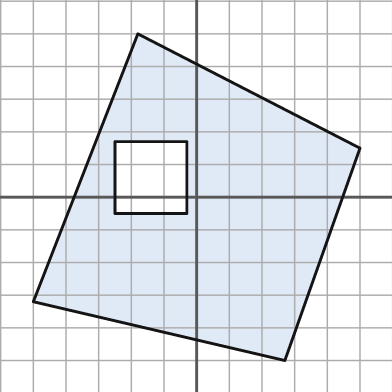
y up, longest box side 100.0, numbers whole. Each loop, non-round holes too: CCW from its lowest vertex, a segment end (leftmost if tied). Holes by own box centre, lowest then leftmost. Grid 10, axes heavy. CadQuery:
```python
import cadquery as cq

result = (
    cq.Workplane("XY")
    .moveTo(27.0, -50.0)
    .lineTo(50.0, 15.0)
    .lineTo(-18.0, 50.0)
    .lineTo(-50.0, -32.0)
    .close()
    .moveTo(-25.0, -5.0)
    .lineTo(-3.0, -5.0)
    .lineTo(-3.0, 17.0)
    .lineTo(-25.0, 17.0)
    .close()
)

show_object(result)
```